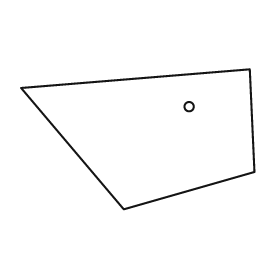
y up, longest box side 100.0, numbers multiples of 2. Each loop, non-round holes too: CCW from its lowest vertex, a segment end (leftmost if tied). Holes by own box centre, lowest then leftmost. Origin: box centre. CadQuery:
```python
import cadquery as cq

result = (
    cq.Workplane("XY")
    .moveTo(-6.0, -30.0)
    .lineTo(50.0, -14.0)
    .lineTo(48.0, 30.0)
    .lineTo(-50.0, 22.0)
    .close()
    .moveTo(22.0, 14.0)
    .circle(2.0)
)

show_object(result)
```